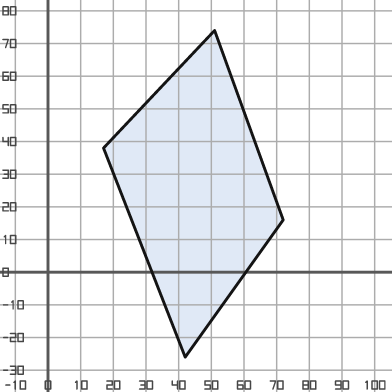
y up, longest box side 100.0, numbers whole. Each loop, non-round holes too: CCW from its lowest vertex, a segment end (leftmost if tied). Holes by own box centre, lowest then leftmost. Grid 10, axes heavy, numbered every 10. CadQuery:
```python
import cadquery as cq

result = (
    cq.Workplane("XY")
    .moveTo(42.0, -26.0)
    .lineTo(72.0, 16.0)
    .lineTo(51.0, 74.0)
    .lineTo(17.0, 38.0)
    .close()
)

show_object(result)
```